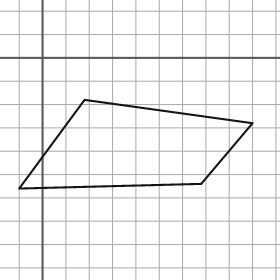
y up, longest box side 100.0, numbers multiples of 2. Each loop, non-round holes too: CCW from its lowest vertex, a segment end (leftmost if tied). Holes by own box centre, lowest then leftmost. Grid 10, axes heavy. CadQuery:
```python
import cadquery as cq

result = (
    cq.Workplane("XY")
    .moveTo(-10.0, -56.0)
    .lineTo(68.0, -54.0)
    .lineTo(90.0, -28.0)
    .lineTo(18.0, -18.0)
    .close()
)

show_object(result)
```